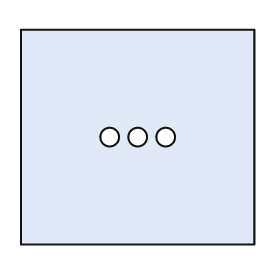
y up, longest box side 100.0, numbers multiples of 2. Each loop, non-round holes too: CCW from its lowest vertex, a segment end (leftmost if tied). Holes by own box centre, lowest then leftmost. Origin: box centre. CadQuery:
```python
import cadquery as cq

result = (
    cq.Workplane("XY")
    .moveTo(-50.0, -46.0)
    .lineTo(50.0, -46.0)
    .lineTo(50.0, 46.0)
    .lineTo(-50.0, 46.0)
    .close()
    .moveTo(-12.0, 0.0)
    .circle(4.0)
    .moveTo(0.0, 0.0)
    .circle(4.0)
    .moveTo(12.0, 0.0)
    .circle(4.0)
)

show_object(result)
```